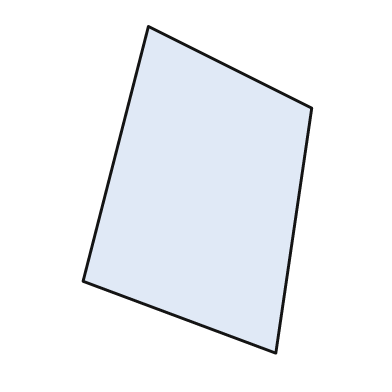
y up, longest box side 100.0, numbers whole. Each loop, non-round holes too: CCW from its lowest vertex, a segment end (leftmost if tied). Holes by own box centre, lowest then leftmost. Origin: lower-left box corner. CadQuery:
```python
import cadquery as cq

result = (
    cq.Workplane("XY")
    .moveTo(59.0, 0.0)
    .lineTo(70.0, 75.0)
    .lineTo(20.0, 100.0)
    .lineTo(0.0, 22.0)
    .close()
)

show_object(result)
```